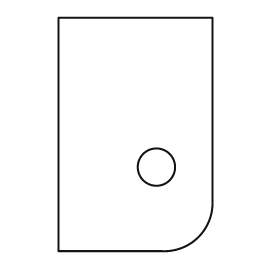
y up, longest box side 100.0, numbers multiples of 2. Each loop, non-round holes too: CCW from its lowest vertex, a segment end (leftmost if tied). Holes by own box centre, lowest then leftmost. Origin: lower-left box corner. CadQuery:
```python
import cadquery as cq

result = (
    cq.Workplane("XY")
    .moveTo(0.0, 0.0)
    .lineTo(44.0, 0.0)
    .threePointArc((60.0, 6.0), (66.0, 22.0))
    .lineTo(66.0, 100.0)
    .lineTo(0.0, 100.0)
    .close()
    .moveTo(42.0, 36.0)
    .circle(8.0)
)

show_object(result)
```